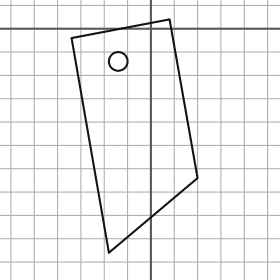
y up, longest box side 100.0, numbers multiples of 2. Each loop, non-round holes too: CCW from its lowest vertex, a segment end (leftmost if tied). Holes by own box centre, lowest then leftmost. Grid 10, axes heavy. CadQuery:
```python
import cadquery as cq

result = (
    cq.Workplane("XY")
    .moveTo(-18.0, -96.0)
    .lineTo(20.0, -64.0)
    .lineTo(8.0, 4.0)
    .lineTo(-34.0, -4.0)
    .close()
    .moveTo(-14.0, -14.0)
    .circle(4.0)
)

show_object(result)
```